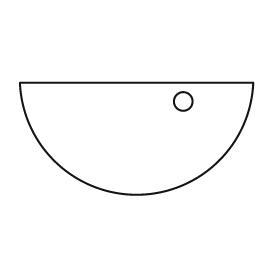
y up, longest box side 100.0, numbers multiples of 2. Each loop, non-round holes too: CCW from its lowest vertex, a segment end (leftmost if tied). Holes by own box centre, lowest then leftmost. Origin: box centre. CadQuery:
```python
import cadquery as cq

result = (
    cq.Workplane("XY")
    .moveTo(-50.0, 24.0)
    .threePointArc((0.0, -24.0), (50.0, 24.0))
    .close()
    .moveTo(20.0, 16.0)
    .circle(4.0)
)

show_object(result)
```